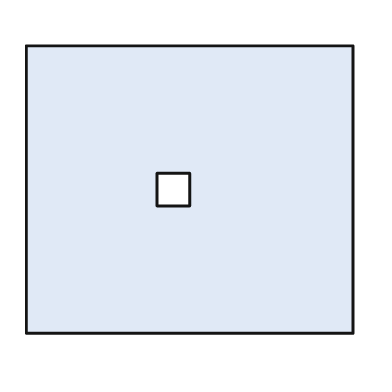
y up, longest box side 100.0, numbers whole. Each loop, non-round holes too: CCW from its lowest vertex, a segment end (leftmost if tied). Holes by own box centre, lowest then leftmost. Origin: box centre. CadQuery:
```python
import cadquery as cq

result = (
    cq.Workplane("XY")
    .moveTo(-50.0, -44.0)
    .lineTo(50.0, -44.0)
    .lineTo(50.0, 44.0)
    .lineTo(-50.0, 44.0)
    .close()
    .moveTo(-10.0, -5.0)
    .lineTo(0.0, -5.0)
    .lineTo(0.0, 5.0)
    .lineTo(-10.0, 5.0)
    .close()
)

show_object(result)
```